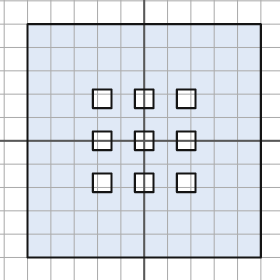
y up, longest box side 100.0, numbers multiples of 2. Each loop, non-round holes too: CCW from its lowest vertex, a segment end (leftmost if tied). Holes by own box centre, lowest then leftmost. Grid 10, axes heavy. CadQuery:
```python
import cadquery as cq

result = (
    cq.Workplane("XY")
    .moveTo(-50.0, -50.0)
    .lineTo(50.0, -50.0)
    .lineTo(50.0, 50.0)
    .lineTo(-50.0, 50.0)
    .close()
    .moveTo(-22.0, -22.0)
    .lineTo(-14.0, -22.0)
    .lineTo(-14.0, -14.0)
    .lineTo(-22.0, -14.0)
    .close()
    .moveTo(-4.0, -22.0)
    .lineTo(4.0, -22.0)
    .lineTo(4.0, -14.0)
    .lineTo(-4.0, -14.0)
    .close()
    .moveTo(14.0, -22.0)
    .lineTo(22.0, -22.0)
    .lineTo(22.0, -14.0)
    .lineTo(14.0, -14.0)
    .close()
    .moveTo(-22.0, -4.0)
    .lineTo(-14.0, -4.0)
    .lineTo(-14.0, 4.0)
    .lineTo(-22.0, 4.0)
    .close()
    .moveTo(-4.0, -4.0)
    .lineTo(4.0, -4.0)
    .lineTo(4.0, 4.0)
    .lineTo(-4.0, 4.0)
    .close()
    .moveTo(14.0, -4.0)
    .lineTo(22.0, -4.0)
    .lineTo(22.0, 4.0)
    .lineTo(14.0, 4.0)
    .close()
    .moveTo(-22.0, 14.0)
    .lineTo(-14.0, 14.0)
    .lineTo(-14.0, 22.0)
    .lineTo(-22.0, 22.0)
    .close()
    .moveTo(-4.0, 14.0)
    .lineTo(4.0, 14.0)
    .lineTo(4.0, 22.0)
    .lineTo(-4.0, 22.0)
    .close()
    .moveTo(14.0, 14.0)
    .lineTo(22.0, 14.0)
    .lineTo(22.0, 22.0)
    .lineTo(14.0, 22.0)
    .close()
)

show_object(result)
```